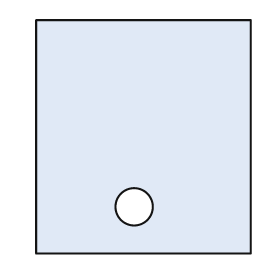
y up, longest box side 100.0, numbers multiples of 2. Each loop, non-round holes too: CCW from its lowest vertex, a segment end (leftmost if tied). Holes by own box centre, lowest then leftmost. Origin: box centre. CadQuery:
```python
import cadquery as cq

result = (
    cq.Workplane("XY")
    .moveTo(-46.0, -50.0)
    .lineTo(46.0, -50.0)
    .lineTo(46.0, 50.0)
    .lineTo(-46.0, 50.0)
    .close()
    .moveTo(-4.0, -30.0)
    .circle(8.0)
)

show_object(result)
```